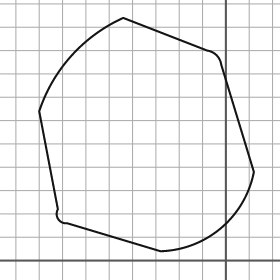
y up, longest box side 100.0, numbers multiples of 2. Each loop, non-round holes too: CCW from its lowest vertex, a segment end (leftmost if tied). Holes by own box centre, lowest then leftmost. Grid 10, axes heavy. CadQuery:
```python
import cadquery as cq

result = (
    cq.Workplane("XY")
    .moveTo(-28.0, 4.0)
    .threePointArc((-2.0, 14.0), (12.0, 38.0))
    .lineTo(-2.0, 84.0)
    .threePointArc((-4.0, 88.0), (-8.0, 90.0))
    .lineTo(-44.0, 104.0)
    .threePointArc((-66.0, 88.0), (-80.0, 64.0))
    .lineTo(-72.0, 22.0)
    .threePointArc((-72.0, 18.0), (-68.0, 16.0))
    .close()
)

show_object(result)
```